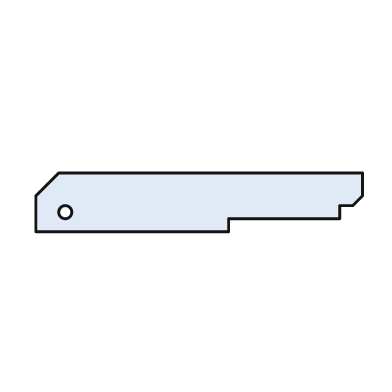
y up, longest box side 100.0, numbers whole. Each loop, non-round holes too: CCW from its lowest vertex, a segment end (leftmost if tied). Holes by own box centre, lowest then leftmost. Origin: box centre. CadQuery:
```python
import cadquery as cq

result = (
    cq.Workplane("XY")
    .moveTo(-50.0, -9.0)
    .lineTo(9.0, -9.0)
    .lineTo(9.0, -5.0)
    .lineTo(43.0, -5.0)
    .lineTo(43.0, -1.0)
    .lineTo(47.0, -1.0)
    .lineTo(50.0, 2.0)
    .lineTo(50.0, 9.0)
    .lineTo(-43.0, 9.0)
    .lineTo(-50.0, 2.0)
    .close()
    .moveTo(-41.0, -3.0)
    .circle(2.0)
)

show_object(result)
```